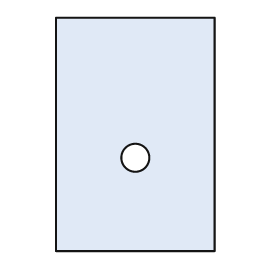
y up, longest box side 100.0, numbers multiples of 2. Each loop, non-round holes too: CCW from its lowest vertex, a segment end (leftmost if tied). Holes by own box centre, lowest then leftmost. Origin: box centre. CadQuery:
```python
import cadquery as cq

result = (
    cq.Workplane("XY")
    .moveTo(-34.0, -50.0)
    .lineTo(34.0, -50.0)
    .lineTo(34.0, 50.0)
    .lineTo(-34.0, 50.0)
    .close()
    .moveTo(0.0, -10.0)
    .circle(6.0)
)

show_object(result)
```